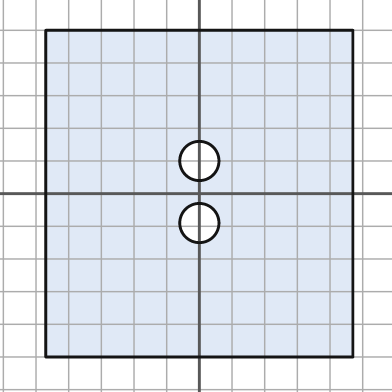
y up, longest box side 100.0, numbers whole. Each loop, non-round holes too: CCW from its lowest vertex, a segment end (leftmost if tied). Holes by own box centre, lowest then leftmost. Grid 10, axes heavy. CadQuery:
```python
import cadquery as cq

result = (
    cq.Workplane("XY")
    .moveTo(-47.0, -50.0)
    .lineTo(47.0, -50.0)
    .lineTo(47.0, 50.0)
    .lineTo(-47.0, 50.0)
    .close()
    .moveTo(0.0, -9.0)
    .circle(6.0)
    .moveTo(0.0, 10.0)
    .circle(6.0)
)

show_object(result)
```